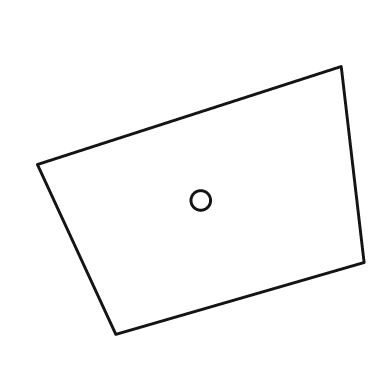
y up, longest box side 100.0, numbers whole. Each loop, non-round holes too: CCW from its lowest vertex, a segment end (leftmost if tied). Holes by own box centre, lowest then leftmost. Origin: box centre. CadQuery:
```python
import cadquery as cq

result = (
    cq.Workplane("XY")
    .moveTo(-26.0, -41.0)
    .lineTo(50.0, -19.0)
    .lineTo(43.0, 41.0)
    .lineTo(-50.0, 11.0)
    .close()
    .moveTo(0.0, 0.0)
    .circle(3.0)
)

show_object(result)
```